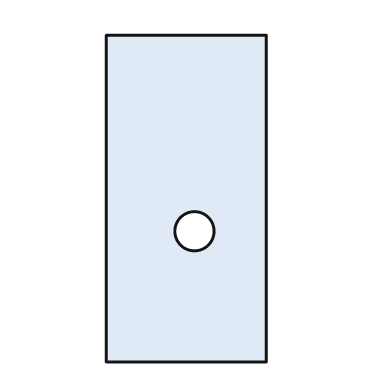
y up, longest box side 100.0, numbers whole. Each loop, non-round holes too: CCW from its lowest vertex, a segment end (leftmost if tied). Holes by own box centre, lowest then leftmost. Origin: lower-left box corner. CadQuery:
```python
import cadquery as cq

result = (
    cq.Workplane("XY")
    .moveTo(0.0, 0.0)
    .lineTo(49.0, 0.0)
    .lineTo(49.0, 100.0)
    .lineTo(0.0, 100.0)
    .close()
    .moveTo(27.0, 40.0)
    .circle(6.0)
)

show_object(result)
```